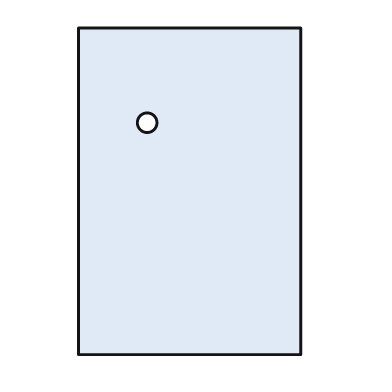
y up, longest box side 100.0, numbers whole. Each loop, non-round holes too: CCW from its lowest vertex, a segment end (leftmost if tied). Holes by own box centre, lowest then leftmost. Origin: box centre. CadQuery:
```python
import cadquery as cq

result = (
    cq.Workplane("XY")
    .moveTo(-34.0, -50.0)
    .lineTo(34.0, -50.0)
    .lineTo(34.0, 50.0)
    .lineTo(-34.0, 50.0)
    .close()
    .moveTo(-13.0, 21.0)
    .circle(3.0)
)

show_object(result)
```